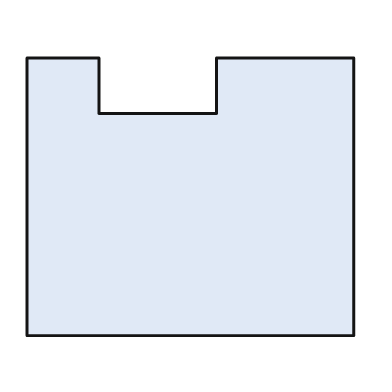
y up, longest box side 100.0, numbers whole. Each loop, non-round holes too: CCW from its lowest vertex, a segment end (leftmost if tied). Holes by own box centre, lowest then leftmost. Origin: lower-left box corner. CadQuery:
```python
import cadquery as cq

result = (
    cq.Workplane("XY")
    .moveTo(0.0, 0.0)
    .lineTo(100.0, 0.0)
    .lineTo(100.0, 85.0)
    .lineTo(58.0, 85.0)
    .lineTo(58.0, 68.0)
    .lineTo(22.0, 68.0)
    .lineTo(22.0, 85.0)
    .lineTo(0.0, 85.0)
    .close()
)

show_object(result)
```